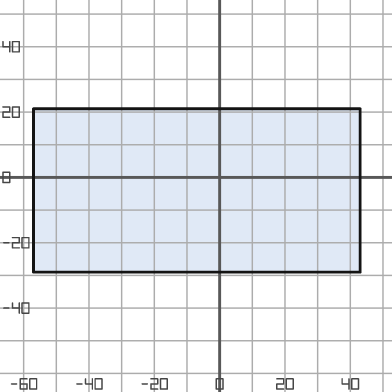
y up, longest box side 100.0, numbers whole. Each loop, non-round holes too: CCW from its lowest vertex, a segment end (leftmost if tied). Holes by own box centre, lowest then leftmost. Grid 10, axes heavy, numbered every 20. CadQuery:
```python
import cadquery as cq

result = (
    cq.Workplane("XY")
    .moveTo(-57.0, -29.0)
    .lineTo(43.0, -29.0)
    .lineTo(43.0, 21.0)
    .lineTo(-57.0, 21.0)
    .close()
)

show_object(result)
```